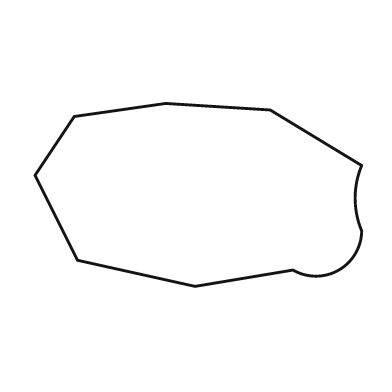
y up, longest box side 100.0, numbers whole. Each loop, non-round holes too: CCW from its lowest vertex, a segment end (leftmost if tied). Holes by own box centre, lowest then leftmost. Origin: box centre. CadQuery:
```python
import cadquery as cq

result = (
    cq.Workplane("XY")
    .moveTo(-1.0, -28.0)
    .lineTo(29.0, -23.0)
    .threePointArc((43.0, -23.0), (50.0, -11.0))
    .threePointArc((48.0, -1.0), (50.0, 9.0))
    .lineTo(22.0, 26.0)
    .lineTo(-10.0, 28.0)
    .lineTo(-38.0, 24.0)
    .lineTo(-50.0, 6.0)
    .lineTo(-37.0, -20.0)
    .close()
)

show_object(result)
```